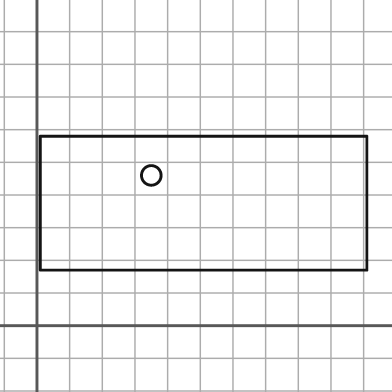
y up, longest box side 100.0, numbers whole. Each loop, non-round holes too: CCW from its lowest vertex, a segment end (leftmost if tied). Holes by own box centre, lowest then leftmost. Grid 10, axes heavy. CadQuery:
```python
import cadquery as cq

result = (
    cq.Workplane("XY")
    .moveTo(1.0, 17.0)
    .lineTo(101.0, 17.0)
    .lineTo(101.0, 58.0)
    .lineTo(1.0, 58.0)
    .close()
    .moveTo(35.0, 46.0)
    .circle(3.0)
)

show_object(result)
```